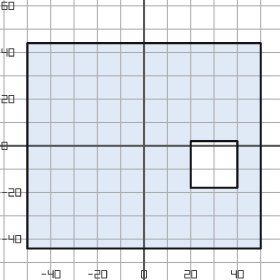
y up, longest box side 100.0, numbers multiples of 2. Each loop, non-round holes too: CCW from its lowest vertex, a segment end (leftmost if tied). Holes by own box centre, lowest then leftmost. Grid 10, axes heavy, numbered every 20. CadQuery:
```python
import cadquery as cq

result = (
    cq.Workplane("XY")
    .moveTo(-50.0, -44.0)
    .lineTo(50.0, -44.0)
    .lineTo(50.0, 44.0)
    .lineTo(-50.0, 44.0)
    .close()
    .moveTo(20.0, -18.0)
    .lineTo(40.0, -18.0)
    .lineTo(40.0, 2.0)
    .lineTo(20.0, 2.0)
    .close()
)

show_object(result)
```